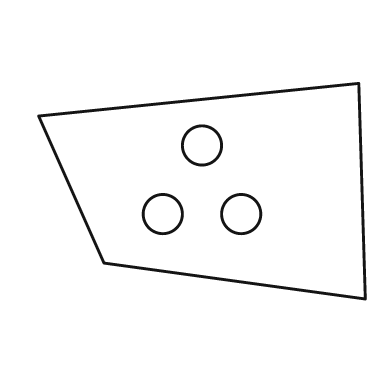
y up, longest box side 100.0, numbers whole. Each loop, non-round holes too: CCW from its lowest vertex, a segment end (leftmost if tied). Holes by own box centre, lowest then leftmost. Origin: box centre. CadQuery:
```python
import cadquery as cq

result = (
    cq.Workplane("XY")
    .moveTo(50.0, -33.0)
    .lineTo(48.0, 33.0)
    .lineTo(-50.0, 23.0)
    .lineTo(-30.0, -22.0)
    .close()
    .moveTo(-12.0, -7.0)
    .circle(6.0)
    .moveTo(12.0, -7.0)
    .circle(6.0)
    .moveTo(0.0, 14.0)
    .circle(6.0)
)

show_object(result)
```